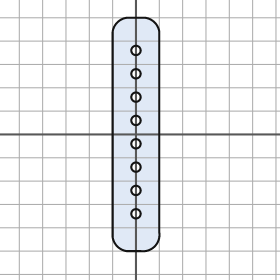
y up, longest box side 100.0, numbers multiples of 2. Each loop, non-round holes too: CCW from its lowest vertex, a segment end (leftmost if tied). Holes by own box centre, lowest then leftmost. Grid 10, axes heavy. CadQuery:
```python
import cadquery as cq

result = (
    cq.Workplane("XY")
    .moveTo(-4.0, -50.0)
    .lineTo(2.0, -50.0)
    .threePointArc((8.0, -48.0), (10.0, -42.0))
    .lineTo(10.0, 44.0)
    .threePointArc((8.0, 48.0), (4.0, 50.0))
    .lineTo(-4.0, 50.0)
    .threePointArc((-8.0, 48.0), (-10.0, 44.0))
    .lineTo(-10.0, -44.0)
    .threePointArc((-8.0, -48.0), (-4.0, -50.0))
    .close()
    .moveTo(0.0, -34.0)
    .circle(2.0)
    .moveTo(0.0, -24.0)
    .circle(2.0)
    .moveTo(0.0, -14.0)
    .circle(2.0)
    .moveTo(0.0, -4.0)
    .circle(2.0)
    .moveTo(0.0, 6.0)
    .circle(2.0)
    .moveTo(0.0, 16.0)
    .circle(2.0)
    .moveTo(0.0, 26.0)
    .circle(2.0)
    .moveTo(0.0, 36.0)
    .circle(2.0)
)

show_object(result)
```